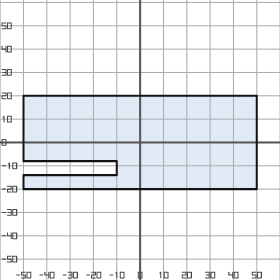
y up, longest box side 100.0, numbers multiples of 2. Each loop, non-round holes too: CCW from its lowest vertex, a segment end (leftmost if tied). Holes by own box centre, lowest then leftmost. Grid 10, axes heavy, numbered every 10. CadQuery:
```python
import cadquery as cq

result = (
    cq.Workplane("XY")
    .moveTo(-50.0, -20.0)
    .lineTo(50.0, -20.0)
    .lineTo(50.0, 20.0)
    .lineTo(-50.0, 20.0)
    .lineTo(-50.0, -8.0)
    .lineTo(-10.0, -8.0)
    .lineTo(-10.0, -14.0)
    .lineTo(-50.0, -14.0)
    .close()
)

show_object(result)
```